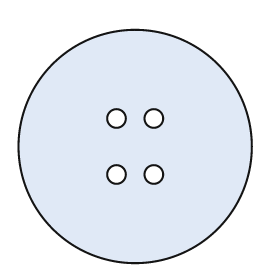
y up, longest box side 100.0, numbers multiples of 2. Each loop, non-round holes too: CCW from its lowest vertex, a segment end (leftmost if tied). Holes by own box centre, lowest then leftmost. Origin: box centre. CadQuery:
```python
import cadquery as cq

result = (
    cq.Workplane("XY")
    .moveTo(0.0, 0.0)
    .circle(50.0)
    .moveTo(-8.0, -12.0)
    .circle(4.0)
    .moveTo(8.0, -12.0)
    .circle(4.0)
    .moveTo(-8.0, 12.0)
    .circle(4.0)
    .moveTo(8.0, 12.0)
    .circle(4.0)
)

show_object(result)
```